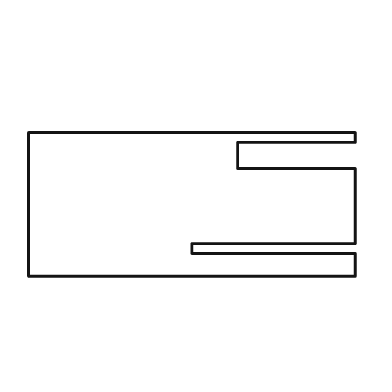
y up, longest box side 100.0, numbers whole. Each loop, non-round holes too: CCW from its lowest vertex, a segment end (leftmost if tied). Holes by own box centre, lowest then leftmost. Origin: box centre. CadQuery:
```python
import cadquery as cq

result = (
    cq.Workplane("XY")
    .moveTo(-50.0, -22.0)
    .lineTo(50.0, -22.0)
    .lineTo(50.0, -15.0)
    .lineTo(0.0, -15.0)
    .lineTo(0.0, -12.0)
    .lineTo(50.0, -12.0)
    .lineTo(50.0, 11.0)
    .lineTo(14.0, 11.0)
    .lineTo(14.0, 19.0)
    .lineTo(50.0, 19.0)
    .lineTo(50.0, 22.0)
    .lineTo(-50.0, 22.0)
    .close()
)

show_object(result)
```